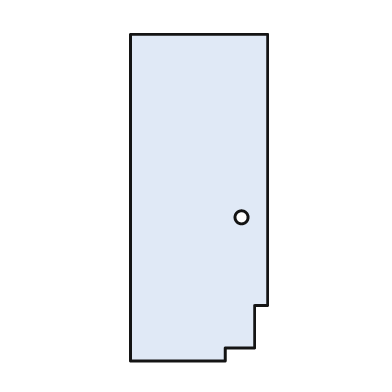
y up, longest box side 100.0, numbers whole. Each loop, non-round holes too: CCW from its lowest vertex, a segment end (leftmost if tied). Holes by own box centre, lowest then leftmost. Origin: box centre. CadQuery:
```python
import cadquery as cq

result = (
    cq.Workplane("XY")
    .moveTo(-21.0, -50.0)
    .lineTo(8.0, -50.0)
    .lineTo(8.0, -46.0)
    .lineTo(17.0, -46.0)
    .lineTo(17.0, -33.0)
    .lineTo(21.0, -33.0)
    .lineTo(21.0, 50.0)
    .lineTo(-21.0, 50.0)
    .close()
    .moveTo(13.0, -6.0)
    .circle(2.0)
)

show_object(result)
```